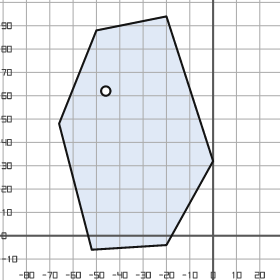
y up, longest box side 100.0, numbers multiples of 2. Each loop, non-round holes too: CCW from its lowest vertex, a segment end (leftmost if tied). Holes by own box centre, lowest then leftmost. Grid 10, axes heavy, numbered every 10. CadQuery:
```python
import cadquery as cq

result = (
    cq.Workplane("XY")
    .moveTo(-52.0, -6.0)
    .lineTo(-20.0, -4.0)
    .lineTo(0.0, 32.0)
    .lineTo(-20.0, 94.0)
    .lineTo(-50.0, 88.0)
    .lineTo(-66.0, 48.0)
    .close()
    .moveTo(-46.0, 62.0)
    .circle(2.0)
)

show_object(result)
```